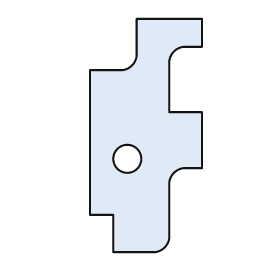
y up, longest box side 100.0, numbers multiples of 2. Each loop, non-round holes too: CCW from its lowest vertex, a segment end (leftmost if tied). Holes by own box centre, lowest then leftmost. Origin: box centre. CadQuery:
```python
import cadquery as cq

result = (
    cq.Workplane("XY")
    .moveTo(-14.0, -50.0)
    .lineTo(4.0, -50.0)
    .threePointArc((8.0, -48.0), (10.0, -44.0))
    .lineTo(10.0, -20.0)
    .threePointArc((12.0, -16.0), (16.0, -14.0))
    .lineTo(24.0, -14.0)
    .lineTo(24.0, 10.0)
    .lineTo(10.0, 10.0)
    .lineTo(10.0, 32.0)
    .threePointArc((12.0, 36.0), (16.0, 38.0))
    .lineTo(24.0, 38.0)
    .lineTo(24.0, 50.0)
    .lineTo(-4.0, 50.0)
    .lineTo(-4.0, 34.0)
    .threePointArc((-6.0, 30.0), (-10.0, 28.0))
    .lineTo(-24.0, 28.0)
    .lineTo(-24.0, -34.0)
    .lineTo(-14.0, -34.0)
    .close()
    .moveTo(-8.0, -10.0)
    .circle(6.0)
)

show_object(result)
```